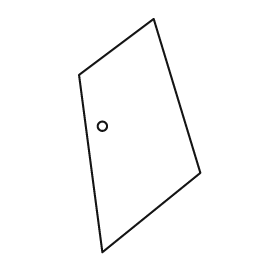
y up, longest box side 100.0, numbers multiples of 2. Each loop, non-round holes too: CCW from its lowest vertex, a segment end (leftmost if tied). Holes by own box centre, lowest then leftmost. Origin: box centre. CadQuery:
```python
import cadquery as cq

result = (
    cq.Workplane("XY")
    .moveTo(-16.0, -50.0)
    .lineTo(26.0, -16.0)
    .lineTo(6.0, 50.0)
    .lineTo(-26.0, 26.0)
    .close()
    .moveTo(-16.0, 4.0)
    .circle(2.0)
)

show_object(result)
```